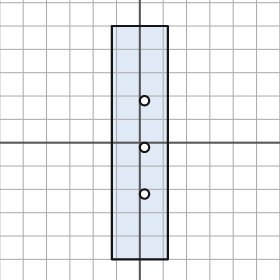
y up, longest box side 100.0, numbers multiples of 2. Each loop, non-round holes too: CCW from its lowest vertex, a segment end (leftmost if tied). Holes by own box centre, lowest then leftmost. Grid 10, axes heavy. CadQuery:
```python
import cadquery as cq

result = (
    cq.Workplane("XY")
    .moveTo(-12.0, -50.0)
    .lineTo(12.0, -50.0)
    .lineTo(12.0, 50.0)
    .lineTo(-12.0, 50.0)
    .close()
    .moveTo(2.0, -22.0)
    .circle(2.0)
    .moveTo(2.0, -2.0)
    .circle(2.0)
    .moveTo(2.0, 18.0)
    .circle(2.0)
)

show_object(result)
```